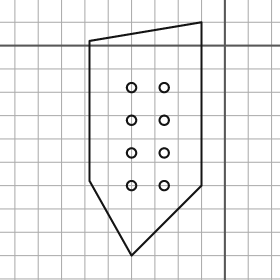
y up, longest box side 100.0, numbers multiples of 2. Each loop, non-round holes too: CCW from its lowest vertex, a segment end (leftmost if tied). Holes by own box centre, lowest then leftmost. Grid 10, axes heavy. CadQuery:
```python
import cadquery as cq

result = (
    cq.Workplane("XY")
    .moveTo(-40.0, -90.0)
    .lineTo(-10.0, -60.0)
    .lineTo(-10.0, 10.0)
    .lineTo(-58.0, 2.0)
    .lineTo(-58.0, -58.0)
    .close()
    .moveTo(-40.0, -60.0)
    .circle(2.0)
    .moveTo(-26.0, -60.0)
    .circle(2.0)
    .moveTo(-40.0, -46.0)
    .circle(2.0)
    .moveTo(-26.0, -46.0)
    .circle(2.0)
    .moveTo(-40.0, -32.0)
    .circle(2.0)
    .moveTo(-26.0, -32.0)
    .circle(2.0)
    .moveTo(-40.0, -18.0)
    .circle(2.0)
    .moveTo(-26.0, -18.0)
    .circle(2.0)
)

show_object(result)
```